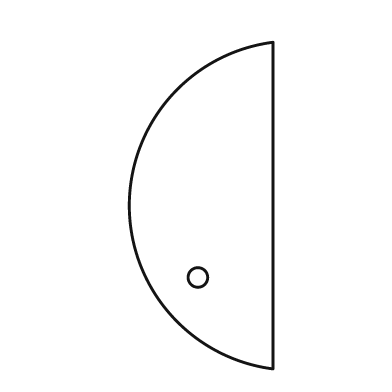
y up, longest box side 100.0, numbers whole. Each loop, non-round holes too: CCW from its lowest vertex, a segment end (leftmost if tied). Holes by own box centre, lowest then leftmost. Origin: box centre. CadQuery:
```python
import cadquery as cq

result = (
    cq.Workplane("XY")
    .moveTo(22.0, -50.0)
    .lineTo(22.0, 50.0)
    .threePointArc((-22.0, 0.0), (22.0, -50.0))
    .close()
    .moveTo(-1.0, -22.0)
    .circle(3.0)
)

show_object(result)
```